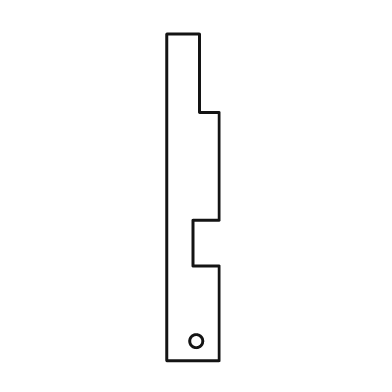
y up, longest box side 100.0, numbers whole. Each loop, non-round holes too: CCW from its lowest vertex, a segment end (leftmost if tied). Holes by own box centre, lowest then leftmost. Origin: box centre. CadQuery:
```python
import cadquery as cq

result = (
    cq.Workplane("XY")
    .moveTo(-8.0, -50.0)
    .lineTo(8.0, -50.0)
    .lineTo(8.0, -21.0)
    .lineTo(0.0, -21.0)
    .lineTo(0.0, -7.0)
    .lineTo(8.0, -7.0)
    .lineTo(8.0, 26.0)
    .lineTo(2.0, 26.0)
    .lineTo(2.0, 50.0)
    .lineTo(-8.0, 50.0)
    .close()
    .moveTo(1.0, -44.0)
    .circle(2.0)
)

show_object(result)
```